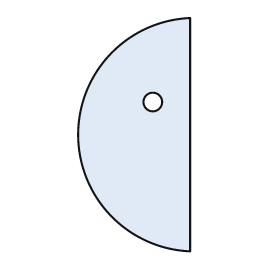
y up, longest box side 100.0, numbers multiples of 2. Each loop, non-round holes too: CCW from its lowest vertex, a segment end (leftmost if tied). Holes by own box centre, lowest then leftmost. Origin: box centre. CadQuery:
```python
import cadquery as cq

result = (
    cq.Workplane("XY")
    .moveTo(24.0, -50.0)
    .lineTo(24.0, 50.0)
    .threePointArc((-24.0, 0.0), (24.0, -50.0))
    .close()
    .moveTo(8.0, 14.0)
    .circle(4.0)
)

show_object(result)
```